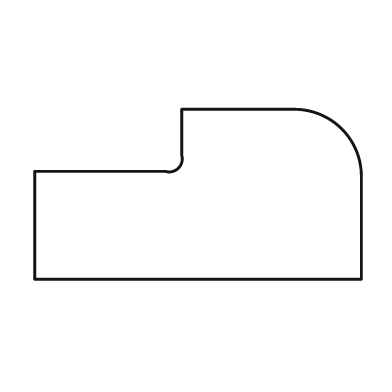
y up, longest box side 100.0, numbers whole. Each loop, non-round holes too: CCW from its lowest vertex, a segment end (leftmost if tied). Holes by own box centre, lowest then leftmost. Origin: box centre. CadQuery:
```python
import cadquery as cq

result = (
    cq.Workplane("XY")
    .moveTo(-50.0, -26.0)
    .lineTo(50.0, -26.0)
    .lineTo(50.0, 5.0)
    .threePointArc((44.0, 20.0), (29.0, 26.0))
    .lineTo(-5.0, 26.0)
    .lineTo(-5.0, 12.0)
    .threePointArc((-6.0, 8.0), (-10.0, 7.0))
    .lineTo(-50.0, 7.0)
    .close()
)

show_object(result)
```